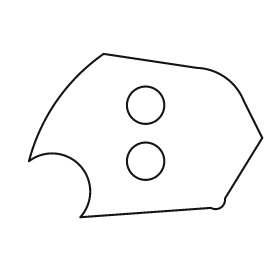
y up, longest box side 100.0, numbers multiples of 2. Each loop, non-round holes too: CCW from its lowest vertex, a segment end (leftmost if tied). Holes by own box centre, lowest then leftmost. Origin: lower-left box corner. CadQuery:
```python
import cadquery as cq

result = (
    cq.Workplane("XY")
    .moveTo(22.0, 0.0)
    .lineTo(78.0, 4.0)
    .threePointArc((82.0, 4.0), (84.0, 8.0))
    .lineTo(100.0, 34.0)
    .lineTo(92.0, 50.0)
    .threePointArc((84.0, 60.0), (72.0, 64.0))
    .lineTo(32.0, 70.0)
    .threePointArc((12.0, 50.0), (0.0, 24.0))
    .threePointArc((22.0, 22.0), (22.0, 0.0))
    .close()
    .moveTo(50.0, 24.0)
    .circle(8.0)
    .moveTo(50.0, 48.0)
    .circle(8.0)
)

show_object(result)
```